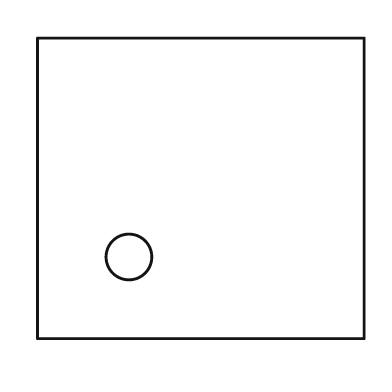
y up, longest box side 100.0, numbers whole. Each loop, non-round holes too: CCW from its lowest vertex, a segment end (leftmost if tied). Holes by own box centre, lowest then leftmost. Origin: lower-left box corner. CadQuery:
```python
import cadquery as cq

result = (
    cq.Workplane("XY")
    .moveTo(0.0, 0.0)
    .lineTo(100.0, 0.0)
    .lineTo(100.0, 92.0)
    .lineTo(0.0, 92.0)
    .close()
    .moveTo(28.0, 25.0)
    .circle(7.0)
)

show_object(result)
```